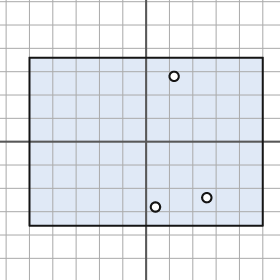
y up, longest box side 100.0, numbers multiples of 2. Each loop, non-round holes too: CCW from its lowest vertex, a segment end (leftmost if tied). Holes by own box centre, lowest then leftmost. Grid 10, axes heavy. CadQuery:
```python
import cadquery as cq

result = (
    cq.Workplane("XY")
    .moveTo(-50.0, -36.0)
    .lineTo(50.0, -36.0)
    .lineTo(50.0, 36.0)
    .lineTo(-50.0, 36.0)
    .close()
    .moveTo(4.0, -28.0)
    .circle(2.0)
    .moveTo(26.0, -24.0)
    .circle(2.0)
    .moveTo(12.0, 28.0)
    .circle(2.0)
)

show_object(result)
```